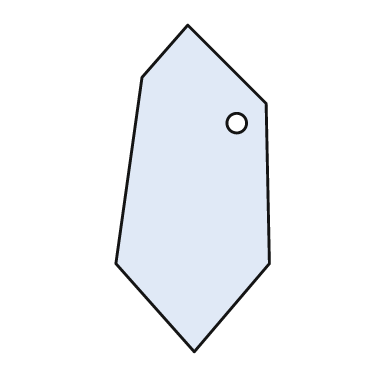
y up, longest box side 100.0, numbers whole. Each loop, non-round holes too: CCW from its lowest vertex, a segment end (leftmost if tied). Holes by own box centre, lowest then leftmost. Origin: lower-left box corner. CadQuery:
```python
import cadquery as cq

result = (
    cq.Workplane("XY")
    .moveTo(24.0, 0.0)
    .lineTo(47.0, 27.0)
    .lineTo(46.0, 76.0)
    .lineTo(22.0, 100.0)
    .lineTo(8.0, 84.0)
    .lineTo(0.0, 27.0)
    .close()
    .moveTo(37.0, 70.0)
    .circle(3.0)
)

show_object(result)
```